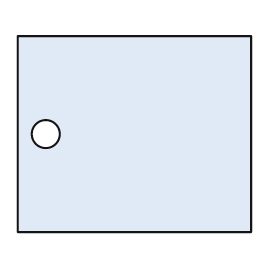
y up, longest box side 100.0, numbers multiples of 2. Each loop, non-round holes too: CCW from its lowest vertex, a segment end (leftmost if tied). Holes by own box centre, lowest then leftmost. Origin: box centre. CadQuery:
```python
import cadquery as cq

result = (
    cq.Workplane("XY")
    .moveTo(-50.0, -42.0)
    .lineTo(50.0, -42.0)
    .lineTo(50.0, 42.0)
    .lineTo(-50.0, 42.0)
    .close()
    .moveTo(-38.0, 0.0)
    .circle(6.0)
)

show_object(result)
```